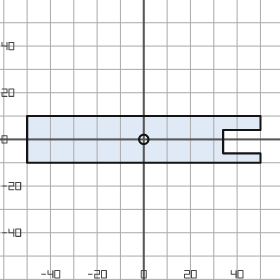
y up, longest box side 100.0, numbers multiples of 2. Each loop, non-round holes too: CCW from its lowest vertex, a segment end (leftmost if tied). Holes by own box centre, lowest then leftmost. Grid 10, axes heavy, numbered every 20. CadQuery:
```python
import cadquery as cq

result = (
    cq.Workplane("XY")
    .moveTo(-50.0, -10.0)
    .lineTo(50.0, -10.0)
    .lineTo(50.0, -6.0)
    .lineTo(34.0, -6.0)
    .lineTo(34.0, 4.0)
    .lineTo(50.0, 4.0)
    .lineTo(50.0, 10.0)
    .lineTo(-50.0, 10.0)
    .close()
    .moveTo(0.0, 0.0)
    .circle(2.0)
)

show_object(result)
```